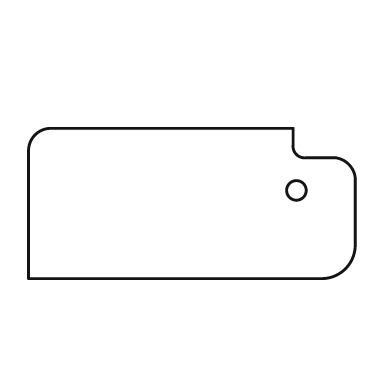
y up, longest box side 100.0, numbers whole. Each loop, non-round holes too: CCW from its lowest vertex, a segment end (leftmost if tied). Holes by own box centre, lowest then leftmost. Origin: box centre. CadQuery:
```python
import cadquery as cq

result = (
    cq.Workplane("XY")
    .moveTo(-50.0, -23.0)
    .lineTo(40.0, -23.0)
    .threePointArc((47.0, -20.0), (50.0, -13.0))
    .lineTo(50.0, 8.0)
    .threePointArc((48.0, 12.0), (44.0, 14.0))
    .lineTo(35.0, 14.0)
    .threePointArc((32.0, 15.0), (31.0, 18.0))
    .lineTo(31.0, 23.0)
    .lineTo(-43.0, 23.0)
    .threePointArc((-48.0, 21.0), (-50.0, 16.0))
    .close()
    .moveTo(32.0, 4.0)
    .circle(3.0)
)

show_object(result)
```